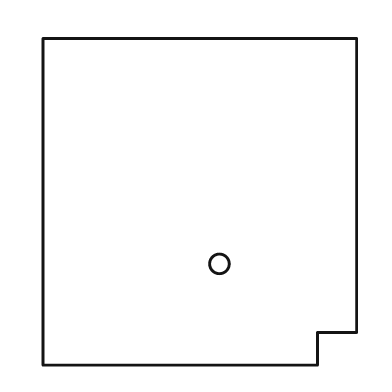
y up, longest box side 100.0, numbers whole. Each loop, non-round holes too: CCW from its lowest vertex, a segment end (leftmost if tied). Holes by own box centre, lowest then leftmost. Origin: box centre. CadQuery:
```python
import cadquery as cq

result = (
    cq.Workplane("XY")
    .moveTo(-48.0, -50.0)
    .lineTo(36.0, -50.0)
    .lineTo(36.0, -40.0)
    .lineTo(48.0, -40.0)
    .lineTo(48.0, 50.0)
    .lineTo(-48.0, 50.0)
    .close()
    .moveTo(6.0, -19.0)
    .circle(3.0)
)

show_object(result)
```